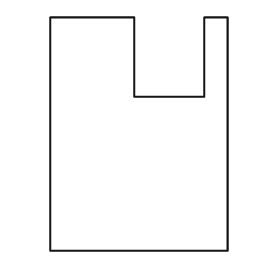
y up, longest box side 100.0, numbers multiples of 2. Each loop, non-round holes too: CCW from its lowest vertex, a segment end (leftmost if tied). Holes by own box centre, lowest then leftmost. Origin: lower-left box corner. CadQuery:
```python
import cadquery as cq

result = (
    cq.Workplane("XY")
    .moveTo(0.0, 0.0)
    .lineTo(76.0, 0.0)
    .lineTo(76.0, 100.0)
    .lineTo(66.0, 100.0)
    .lineTo(66.0, 66.0)
    .lineTo(36.0, 66.0)
    .lineTo(36.0, 100.0)
    .lineTo(0.0, 100.0)
    .close()
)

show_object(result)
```